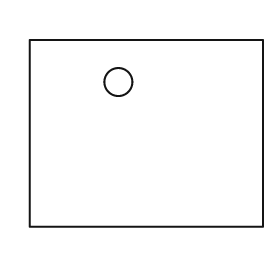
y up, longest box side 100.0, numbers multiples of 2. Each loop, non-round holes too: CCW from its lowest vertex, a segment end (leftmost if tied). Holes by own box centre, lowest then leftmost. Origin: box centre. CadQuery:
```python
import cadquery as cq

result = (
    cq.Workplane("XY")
    .moveTo(-50.0, -40.0)
    .lineTo(50.0, -40.0)
    .lineTo(50.0, 40.0)
    .lineTo(-50.0, 40.0)
    .close()
    .moveTo(-12.0, 22.0)
    .circle(6.0)
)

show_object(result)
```